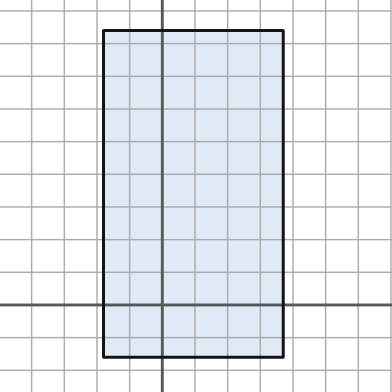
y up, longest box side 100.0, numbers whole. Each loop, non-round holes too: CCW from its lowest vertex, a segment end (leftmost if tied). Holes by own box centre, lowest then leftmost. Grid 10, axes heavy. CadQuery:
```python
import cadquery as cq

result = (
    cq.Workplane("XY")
    .moveTo(-18.0, -16.0)
    .lineTo(37.0, -16.0)
    .lineTo(37.0, 84.0)
    .lineTo(-18.0, 84.0)
    .close()
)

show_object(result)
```